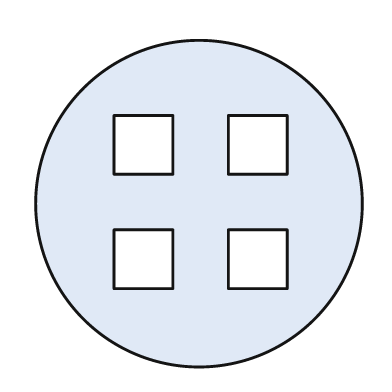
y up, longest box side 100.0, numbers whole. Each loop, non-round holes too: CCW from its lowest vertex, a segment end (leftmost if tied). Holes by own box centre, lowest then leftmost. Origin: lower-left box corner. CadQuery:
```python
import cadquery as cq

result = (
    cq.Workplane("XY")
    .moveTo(50.0, 50.0)
    .circle(50.0)
    .moveTo(24.0, 24.0)
    .lineTo(42.0, 24.0)
    .lineTo(42.0, 42.0)
    .lineTo(24.0, 42.0)
    .close()
    .moveTo(59.0, 24.0)
    .lineTo(77.0, 24.0)
    .lineTo(77.0, 42.0)
    .lineTo(59.0, 42.0)
    .close()
    .moveTo(24.0, 59.0)
    .lineTo(42.0, 59.0)
    .lineTo(42.0, 77.0)
    .lineTo(24.0, 77.0)
    .close()
    .moveTo(59.0, 59.0)
    .lineTo(77.0, 59.0)
    .lineTo(77.0, 77.0)
    .lineTo(59.0, 77.0)
    .close()
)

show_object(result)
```